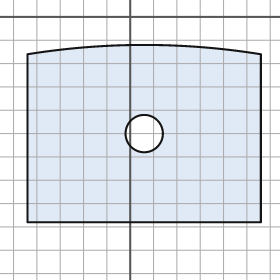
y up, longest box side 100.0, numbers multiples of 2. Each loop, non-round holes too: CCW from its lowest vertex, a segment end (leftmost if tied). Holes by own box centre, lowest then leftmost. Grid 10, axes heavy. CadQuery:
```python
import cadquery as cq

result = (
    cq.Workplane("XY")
    .moveTo(-44.0, -88.0)
    .lineTo(56.0, -88.0)
    .lineTo(56.0, -16.0)
    .threePointArc((6.0, -12.0), (-44.0, -16.0))
    .close()
    .moveTo(6.0, -50.0)
    .circle(8.0)
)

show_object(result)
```